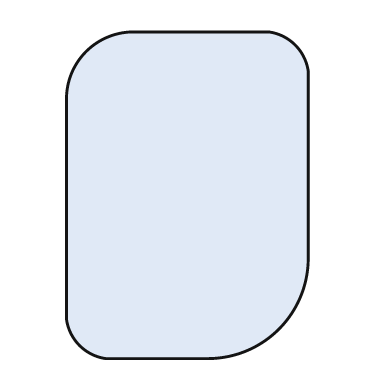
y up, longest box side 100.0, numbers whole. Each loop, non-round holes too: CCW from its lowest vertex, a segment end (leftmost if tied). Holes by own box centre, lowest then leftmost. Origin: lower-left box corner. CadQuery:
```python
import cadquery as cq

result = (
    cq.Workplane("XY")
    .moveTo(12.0, 0.0)
    .lineTo(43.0, 0.0)
    .threePointArc((65.0, 9.0), (74.0, 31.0))
    .lineTo(74.0, 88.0)
    .threePointArc((70.0, 96.0), (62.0, 100.0))
    .lineTo(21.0, 100.0)
    .threePointArc((6.0, 94.0), (0.0, 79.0))
    .lineTo(0.0, 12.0)
    .threePointArc((4.0, 4.0), (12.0, 0.0))
    .close()
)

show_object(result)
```